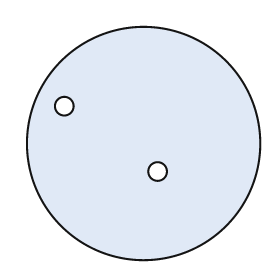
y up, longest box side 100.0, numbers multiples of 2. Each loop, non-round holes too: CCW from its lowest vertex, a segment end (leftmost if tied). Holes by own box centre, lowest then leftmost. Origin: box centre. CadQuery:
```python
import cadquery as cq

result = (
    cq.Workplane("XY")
    .moveTo(0.0, 0.0)
    .circle(50.0)
    .moveTo(6.0, -12.0)
    .circle(4.0)
    .moveTo(-34.0, 16.0)
    .circle(4.0)
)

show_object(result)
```